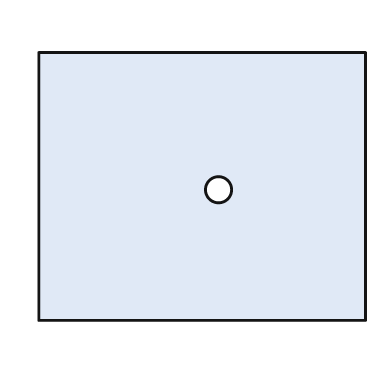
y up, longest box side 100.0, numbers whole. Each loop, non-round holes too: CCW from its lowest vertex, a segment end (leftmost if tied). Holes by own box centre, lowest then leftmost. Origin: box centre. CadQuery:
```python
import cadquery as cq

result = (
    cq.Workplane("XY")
    .moveTo(-50.0, -41.0)
    .lineTo(50.0, -41.0)
    .lineTo(50.0, 41.0)
    .lineTo(-50.0, 41.0)
    .close()
    .moveTo(5.0, -1.0)
    .circle(4.0)
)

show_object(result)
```